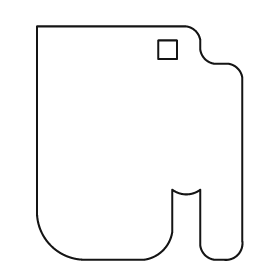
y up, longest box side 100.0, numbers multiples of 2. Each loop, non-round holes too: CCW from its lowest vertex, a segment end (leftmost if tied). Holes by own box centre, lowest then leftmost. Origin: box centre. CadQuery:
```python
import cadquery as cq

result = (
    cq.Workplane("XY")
    .moveTo(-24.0, -50.0)
    .lineTo(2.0, -50.0)
    .threePointArc((10.0, -46.0), (14.0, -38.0))
    .lineTo(14.0, -20.0)
    .threePointArc((20.0, -22.0), (26.0, -20.0))
    .lineTo(26.0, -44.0)
    .threePointArc((28.0, -48.0), (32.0, -50.0))
    .lineTo(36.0, -50.0)
    .threePointArc((42.0, -48.0), (44.0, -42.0))
    .lineTo(44.0, 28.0)
    .threePointArc((42.0, 32.0), (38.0, 34.0))
    .lineTo(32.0, 34.0)
    .threePointArc((28.0, 36.0), (26.0, 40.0))
    .lineTo(26.0, 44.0)
    .threePointArc((24.0, 48.0), (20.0, 50.0))
    .lineTo(-44.0, 50.0)
    .lineTo(-44.0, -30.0)
    .threePointArc((-38.0, -44.0), (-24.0, -50.0))
    .close()
    .moveTo(8.0, 36.0)
    .lineTo(16.0, 36.0)
    .lineTo(16.0, 44.0)
    .lineTo(8.0, 44.0)
    .close()
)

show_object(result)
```